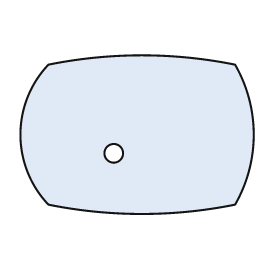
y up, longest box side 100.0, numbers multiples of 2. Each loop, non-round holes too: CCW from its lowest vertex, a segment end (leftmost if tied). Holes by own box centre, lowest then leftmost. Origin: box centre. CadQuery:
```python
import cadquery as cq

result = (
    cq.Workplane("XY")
    .moveTo(-38.0, -30.0)
    .threePointArc((2.0, -34.0), (42.0, -30.0))
    .threePointArc((50.0, 0.0), (42.0, 30.0))
    .threePointArc((2.0, 34.0), (-38.0, 30.0))
    .threePointArc((-50.0, 0.0), (-38.0, -30.0))
    .close()
    .moveTo(-10.0, -8.0)
    .circle(4.0)
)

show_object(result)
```